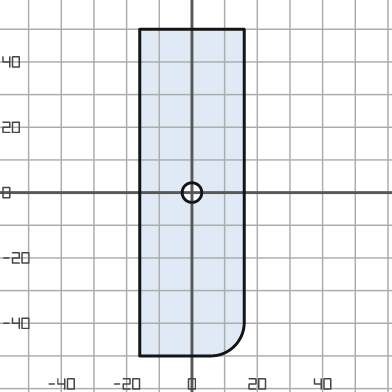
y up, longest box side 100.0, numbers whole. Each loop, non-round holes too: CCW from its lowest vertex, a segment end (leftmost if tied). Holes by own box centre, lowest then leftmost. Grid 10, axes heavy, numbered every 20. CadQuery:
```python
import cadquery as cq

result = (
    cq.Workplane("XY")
    .moveTo(-16.0, -50.0)
    .lineTo(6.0, -50.0)
    .threePointArc((13.0, -47.0), (16.0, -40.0))
    .lineTo(16.0, 50.0)
    .lineTo(-16.0, 50.0)
    .close()
    .moveTo(0.0, 0.0)
    .circle(3.0)
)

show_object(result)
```